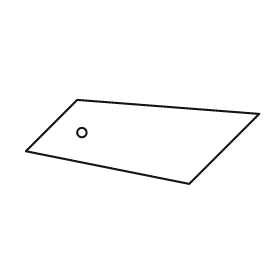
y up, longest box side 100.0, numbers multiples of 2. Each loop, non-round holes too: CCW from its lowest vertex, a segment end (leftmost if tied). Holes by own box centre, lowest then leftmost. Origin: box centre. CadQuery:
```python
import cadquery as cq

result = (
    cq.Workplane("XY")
    .moveTo(20.0, -18.0)
    .lineTo(50.0, 12.0)
    .lineTo(-28.0, 18.0)
    .lineTo(-50.0, -4.0)
    .close()
    .moveTo(-26.0, 4.0)
    .circle(2.0)
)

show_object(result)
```